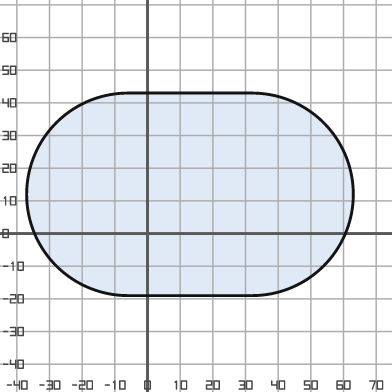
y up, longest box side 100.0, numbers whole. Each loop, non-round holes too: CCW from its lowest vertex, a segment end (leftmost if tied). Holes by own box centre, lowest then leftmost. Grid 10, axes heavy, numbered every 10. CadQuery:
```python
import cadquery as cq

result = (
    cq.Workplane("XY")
    .moveTo(-6.0, -19.0)
    .lineTo(32.0, -19.0)
    .threePointArc((63.0, 12.0), (32.0, 43.0))
    .lineTo(-6.0, 43.0)
    .threePointArc((-37.0, 12.0), (-6.0, -19.0))
    .close()
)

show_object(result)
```